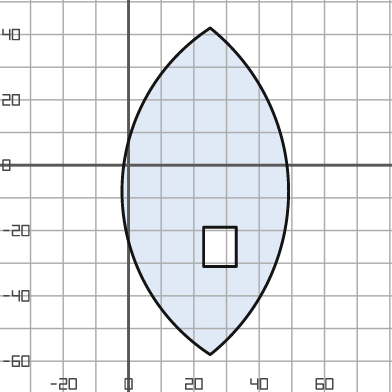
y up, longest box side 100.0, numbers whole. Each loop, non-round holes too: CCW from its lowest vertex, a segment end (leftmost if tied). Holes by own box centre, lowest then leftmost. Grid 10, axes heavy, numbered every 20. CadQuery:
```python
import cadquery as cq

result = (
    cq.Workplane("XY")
    .moveTo(25.0, -58.0)
    .threePointArc((49.0, -8.0), (25.0, 42.0))
    .threePointArc((-2.0, -8.0), (25.0, -58.0))
    .close()
    .moveTo(23.0, -31.0)
    .lineTo(33.0, -31.0)
    .lineTo(33.0, -19.0)
    .lineTo(23.0, -19.0)
    .close()
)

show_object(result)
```